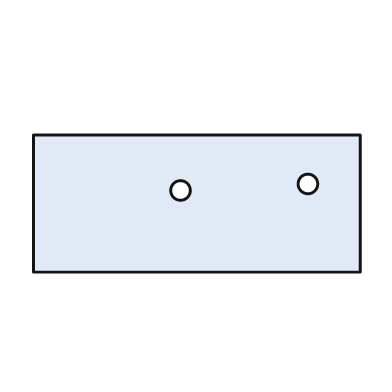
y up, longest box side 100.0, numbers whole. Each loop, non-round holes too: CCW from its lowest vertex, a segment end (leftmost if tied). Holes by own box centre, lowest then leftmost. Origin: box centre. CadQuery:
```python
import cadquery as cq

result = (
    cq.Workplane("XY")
    .moveTo(-50.0, -21.0)
    .lineTo(50.0, -21.0)
    .lineTo(50.0, 21.0)
    .lineTo(-50.0, 21.0)
    .close()
    .moveTo(-5.0, 4.0)
    .circle(3.0)
    .moveTo(34.0, 6.0)
    .circle(3.0)
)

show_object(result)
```